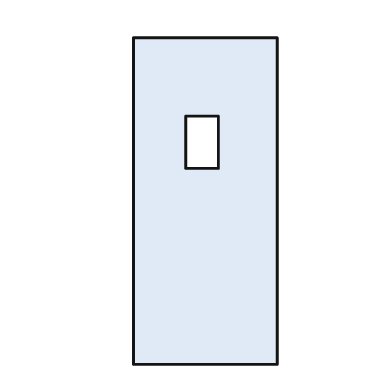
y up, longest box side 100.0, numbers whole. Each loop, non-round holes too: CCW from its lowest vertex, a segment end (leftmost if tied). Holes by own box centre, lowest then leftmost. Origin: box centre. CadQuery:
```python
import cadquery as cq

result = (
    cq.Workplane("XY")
    .moveTo(-22.0, -50.0)
    .lineTo(22.0, -50.0)
    .lineTo(22.0, 50.0)
    .lineTo(-22.0, 50.0)
    .close()
    .moveTo(-6.0, 10.0)
    .lineTo(4.0, 10.0)
    .lineTo(4.0, 26.0)
    .lineTo(-6.0, 26.0)
    .close()
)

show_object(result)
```